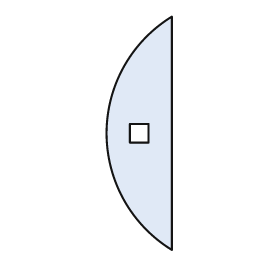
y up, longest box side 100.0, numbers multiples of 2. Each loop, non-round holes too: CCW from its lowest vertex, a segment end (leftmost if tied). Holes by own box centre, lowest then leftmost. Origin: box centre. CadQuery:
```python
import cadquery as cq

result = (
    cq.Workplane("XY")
    .moveTo(14.0, -50.0)
    .lineTo(14.0, 50.0)
    .threePointArc((-14.0, 0.0), (14.0, -50.0))
    .close()
    .moveTo(-4.0, -4.0)
    .lineTo(4.0, -4.0)
    .lineTo(4.0, 4.0)
    .lineTo(-4.0, 4.0)
    .close()
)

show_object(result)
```